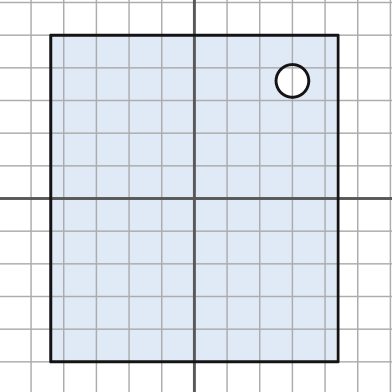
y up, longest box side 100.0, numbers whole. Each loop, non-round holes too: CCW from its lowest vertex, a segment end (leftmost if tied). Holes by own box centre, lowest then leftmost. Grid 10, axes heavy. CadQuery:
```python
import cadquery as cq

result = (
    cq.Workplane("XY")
    .moveTo(-44.0, -50.0)
    .lineTo(44.0, -50.0)
    .lineTo(44.0, 50.0)
    .lineTo(-44.0, 50.0)
    .close()
    .moveTo(30.0, 36.0)
    .circle(5.0)
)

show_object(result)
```